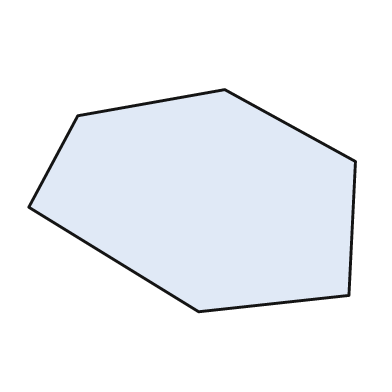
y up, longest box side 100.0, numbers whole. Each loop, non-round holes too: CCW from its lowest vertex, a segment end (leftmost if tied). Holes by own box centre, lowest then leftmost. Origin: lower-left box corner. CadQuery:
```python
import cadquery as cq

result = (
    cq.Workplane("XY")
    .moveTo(52.0, 0.0)
    .lineTo(98.0, 5.0)
    .lineTo(100.0, 46.0)
    .lineTo(60.0, 68.0)
    .lineTo(15.0, 60.0)
    .lineTo(0.0, 32.0)
    .close()
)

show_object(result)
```